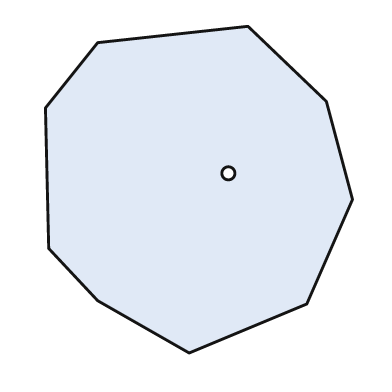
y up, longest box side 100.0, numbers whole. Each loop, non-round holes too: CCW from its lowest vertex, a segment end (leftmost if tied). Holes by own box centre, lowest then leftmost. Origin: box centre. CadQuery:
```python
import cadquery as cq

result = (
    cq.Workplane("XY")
    .moveTo(-3.0, -50.0)
    .lineTo(33.0, -35.0)
    .lineTo(47.0, -3.0)
    .lineTo(39.0, 27.0)
    .lineTo(15.0, 50.0)
    .lineTo(-31.0, 45.0)
    .lineTo(-47.0, 25.0)
    .lineTo(-46.0, -18.0)
    .lineTo(-31.0, -34.0)
    .close()
    .moveTo(9.0, 5.0)
    .circle(2.0)
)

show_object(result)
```